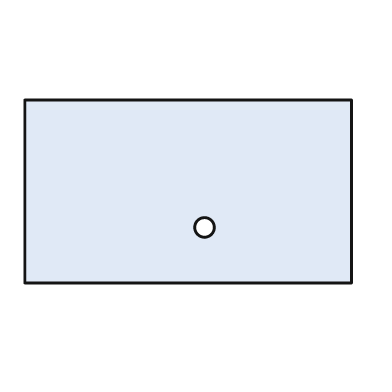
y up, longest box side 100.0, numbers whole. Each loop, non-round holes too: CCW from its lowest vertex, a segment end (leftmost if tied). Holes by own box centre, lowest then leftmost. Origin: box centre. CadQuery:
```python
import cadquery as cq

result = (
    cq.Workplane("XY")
    .moveTo(-50.0, -28.0)
    .lineTo(50.0, -28.0)
    .lineTo(50.0, 28.0)
    .lineTo(-50.0, 28.0)
    .close()
    .moveTo(5.0, -11.0)
    .circle(3.0)
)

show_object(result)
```